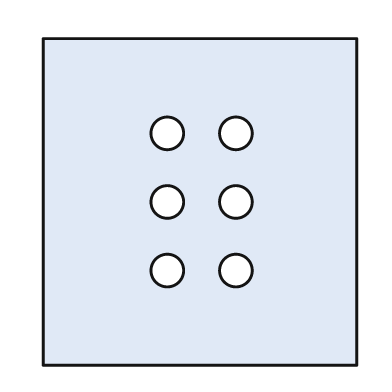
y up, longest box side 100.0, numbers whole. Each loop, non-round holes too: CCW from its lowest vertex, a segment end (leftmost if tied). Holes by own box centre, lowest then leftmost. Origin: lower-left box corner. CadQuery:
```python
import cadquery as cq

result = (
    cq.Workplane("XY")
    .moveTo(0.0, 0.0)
    .lineTo(96.0, 0.0)
    .lineTo(96.0, 100.0)
    .lineTo(0.0, 100.0)
    .close()
    .moveTo(38.0, 29.0)
    .circle(5.0)
    .moveTo(59.0, 29.0)
    .circle(5.0)
    .moveTo(38.0, 50.0)
    .circle(5.0)
    .moveTo(59.0, 50.0)
    .circle(5.0)
    .moveTo(38.0, 71.0)
    .circle(5.0)
    .moveTo(59.0, 71.0)
    .circle(5.0)
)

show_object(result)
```